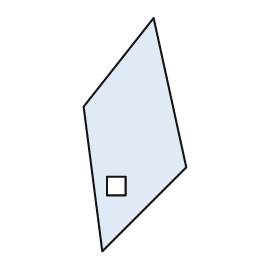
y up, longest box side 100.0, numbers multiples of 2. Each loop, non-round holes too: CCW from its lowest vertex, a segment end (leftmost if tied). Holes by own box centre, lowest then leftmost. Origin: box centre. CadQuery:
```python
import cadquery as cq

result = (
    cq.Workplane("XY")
    .moveTo(-14.0, -50.0)
    .lineTo(22.0, -14.0)
    .lineTo(8.0, 50.0)
    .lineTo(-22.0, 12.0)
    .close()
    .moveTo(-12.0, -26.0)
    .lineTo(-4.0, -26.0)
    .lineTo(-4.0, -18.0)
    .lineTo(-12.0, -18.0)
    .close()
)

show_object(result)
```